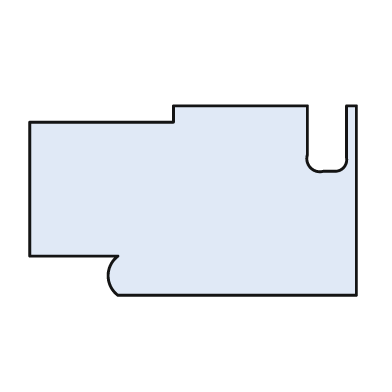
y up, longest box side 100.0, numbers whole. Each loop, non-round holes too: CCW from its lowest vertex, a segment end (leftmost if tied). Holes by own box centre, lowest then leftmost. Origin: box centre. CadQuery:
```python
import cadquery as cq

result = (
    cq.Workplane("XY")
    .moveTo(-23.0, -29.0)
    .lineTo(50.0, -29.0)
    .lineTo(50.0, 29.0)
    .lineTo(47.0, 29.0)
    .lineTo(47.0, 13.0)
    .threePointArc((46.0, 10.0), (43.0, 9.0))
    .lineTo(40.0, 9.0)
    .threePointArc((36.0, 10.0), (35.0, 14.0))
    .lineTo(35.0, 29.0)
    .lineTo(-6.0, 29.0)
    .lineTo(-6.0, 24.0)
    .lineTo(-50.0, 24.0)
    .lineTo(-50.0, -17.0)
    .lineTo(-23.0, -17.0)
    .threePointArc((-26.0, -23.0), (-23.0, -29.0))
    .close()
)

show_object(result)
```